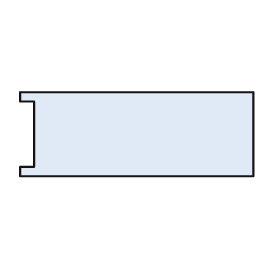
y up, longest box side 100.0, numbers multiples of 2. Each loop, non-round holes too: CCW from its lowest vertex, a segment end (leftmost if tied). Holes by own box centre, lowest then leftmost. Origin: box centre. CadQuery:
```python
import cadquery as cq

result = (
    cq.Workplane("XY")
    .moveTo(-50.0, -18.0)
    .lineTo(50.0, -18.0)
    .lineTo(50.0, 18.0)
    .lineTo(-50.0, 18.0)
    .lineTo(-50.0, 14.0)
    .lineTo(-44.0, 14.0)
    .lineTo(-44.0, -14.0)
    .lineTo(-50.0, -14.0)
    .close()
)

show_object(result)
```